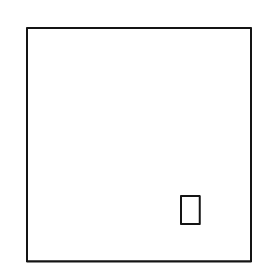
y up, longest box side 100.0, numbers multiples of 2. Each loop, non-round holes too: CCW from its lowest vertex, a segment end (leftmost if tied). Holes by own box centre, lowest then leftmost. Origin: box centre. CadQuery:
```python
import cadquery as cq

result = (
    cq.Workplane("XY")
    .moveTo(-48.0, -50.0)
    .lineTo(48.0, -50.0)
    .lineTo(48.0, 50.0)
    .lineTo(-48.0, 50.0)
    .close()
    .moveTo(18.0, -34.0)
    .lineTo(26.0, -34.0)
    .lineTo(26.0, -22.0)
    .lineTo(18.0, -22.0)
    .close()
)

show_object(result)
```